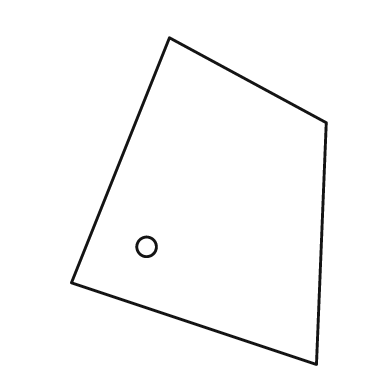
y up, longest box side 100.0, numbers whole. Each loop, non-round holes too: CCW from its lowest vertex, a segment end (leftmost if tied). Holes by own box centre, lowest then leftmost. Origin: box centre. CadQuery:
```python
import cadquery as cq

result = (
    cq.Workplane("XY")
    .moveTo(36.0, -50.0)
    .lineTo(39.0, 24.0)
    .lineTo(-9.0, 50.0)
    .lineTo(-39.0, -25.0)
    .close()
    .moveTo(-16.0, -14.0)
    .circle(3.0)
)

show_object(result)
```